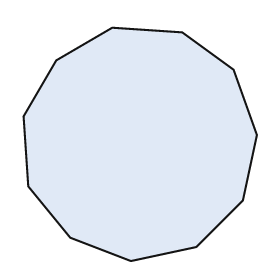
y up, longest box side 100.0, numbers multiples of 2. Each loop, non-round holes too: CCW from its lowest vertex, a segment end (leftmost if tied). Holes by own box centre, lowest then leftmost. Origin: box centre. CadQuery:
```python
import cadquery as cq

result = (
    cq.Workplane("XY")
    .moveTo(-4.0, -50.0)
    .lineTo(24.0, -44.0)
    .lineTo(44.0, -24.0)
    .lineTo(50.0, 4.0)
    .lineTo(40.0, 32.0)
    .lineTo(18.0, 48.0)
    .lineTo(-12.0, 50.0)
    .lineTo(-36.0, 36.0)
    .lineTo(-50.0, 12.0)
    .lineTo(-48.0, -18.0)
    .lineTo(-30.0, -40.0)
    .close()
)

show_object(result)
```